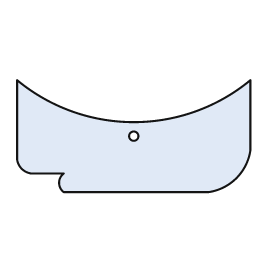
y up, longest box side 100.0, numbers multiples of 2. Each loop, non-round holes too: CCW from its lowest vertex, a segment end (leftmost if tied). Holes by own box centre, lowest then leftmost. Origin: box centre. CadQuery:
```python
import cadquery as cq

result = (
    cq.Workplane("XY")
    .moveTo(-30.0, -24.0)
    .lineTo(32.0, -24.0)
    .threePointArc((44.0, -18.0), (50.0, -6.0))
    .lineTo(50.0, 24.0)
    .threePointArc((0.0, 6.0), (-50.0, 24.0))
    .lineTo(-50.0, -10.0)
    .threePointArc((-48.0, -14.0), (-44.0, -16.0))
    .lineTo(-30.0, -16.0)
    .threePointArc((-32.0, -20.0), (-30.0, -24.0))
    .close()
    .moveTo(0.0, 0.0)
    .circle(2.0)
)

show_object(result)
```